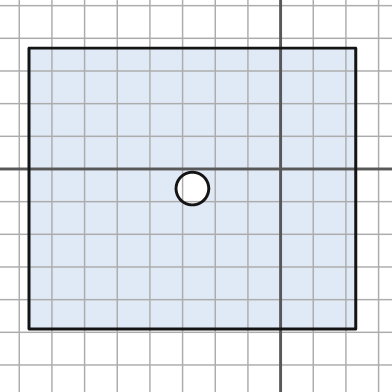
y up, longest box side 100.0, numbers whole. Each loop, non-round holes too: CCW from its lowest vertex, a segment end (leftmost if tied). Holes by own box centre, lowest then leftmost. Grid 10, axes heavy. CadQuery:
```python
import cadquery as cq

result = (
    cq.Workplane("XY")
    .moveTo(-77.0, -49.0)
    .lineTo(23.0, -49.0)
    .lineTo(23.0, 37.0)
    .lineTo(-77.0, 37.0)
    .close()
    .moveTo(-27.0, -6.0)
    .circle(5.0)
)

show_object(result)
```